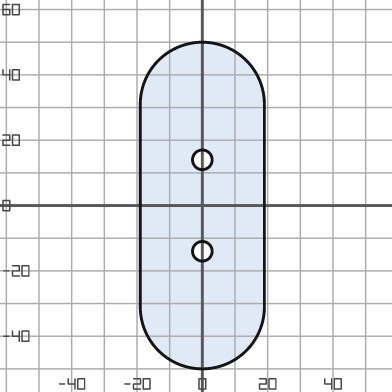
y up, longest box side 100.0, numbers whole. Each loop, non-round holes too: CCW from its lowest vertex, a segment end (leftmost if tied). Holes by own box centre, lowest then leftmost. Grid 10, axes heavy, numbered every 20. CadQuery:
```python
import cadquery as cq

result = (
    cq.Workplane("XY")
    .moveTo(-19.0, -31.0)
    .threePointArc((0.0, -50.0), (19.0, -31.0))
    .lineTo(19.0, 31.0)
    .threePointArc((0.0, 50.0), (-19.0, 31.0))
    .close()
    .moveTo(0.0, -14.0)
    .circle(3.0)
    .moveTo(0.0, 14.0)
    .circle(3.0)
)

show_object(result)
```